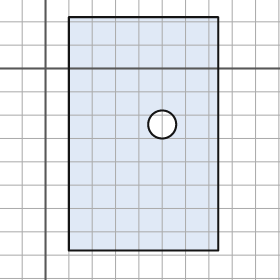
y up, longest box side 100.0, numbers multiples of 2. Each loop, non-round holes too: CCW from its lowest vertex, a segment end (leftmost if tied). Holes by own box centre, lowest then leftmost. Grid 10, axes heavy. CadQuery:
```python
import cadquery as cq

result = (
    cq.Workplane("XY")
    .moveTo(10.0, -78.0)
    .lineTo(74.0, -78.0)
    .lineTo(74.0, 22.0)
    .lineTo(10.0, 22.0)
    .close()
    .moveTo(50.0, -24.0)
    .circle(6.0)
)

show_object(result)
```